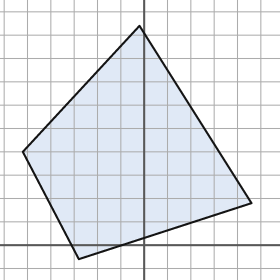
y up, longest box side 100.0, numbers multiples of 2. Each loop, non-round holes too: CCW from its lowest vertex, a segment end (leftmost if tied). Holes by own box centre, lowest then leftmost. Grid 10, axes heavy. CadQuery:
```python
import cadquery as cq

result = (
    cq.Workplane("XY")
    .moveTo(-28.0, -6.0)
    .lineTo(46.0, 18.0)
    .lineTo(-2.0, 94.0)
    .lineTo(-52.0, 40.0)
    .close()
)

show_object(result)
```